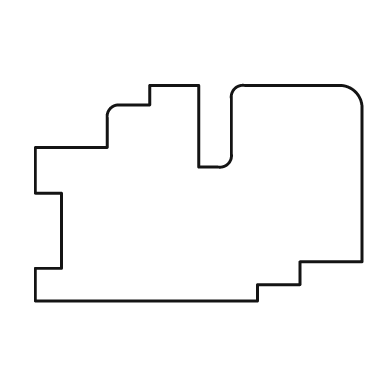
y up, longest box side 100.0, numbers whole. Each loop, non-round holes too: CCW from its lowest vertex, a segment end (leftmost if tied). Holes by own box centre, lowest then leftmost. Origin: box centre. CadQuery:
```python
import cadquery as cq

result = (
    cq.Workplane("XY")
    .moveTo(-50.0, -33.0)
    .lineTo(18.0, -33.0)
    .lineTo(18.0, -28.0)
    .lineTo(31.0, -28.0)
    .lineTo(31.0, -21.0)
    .lineTo(50.0, -21.0)
    .lineTo(50.0, 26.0)
    .threePointArc((48.0, 31.0), (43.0, 33.0))
    .lineTo(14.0, 33.0)
    .threePointArc((11.0, 32.0), (10.0, 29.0))
    .lineTo(10.0, 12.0)
    .threePointArc((9.0, 9.0), (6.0, 8.0))
    .lineTo(0.0, 8.0)
    .lineTo(0.0, 33.0)
    .lineTo(-15.0, 33.0)
    .lineTo(-15.0, 27.0)
    .lineTo(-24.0, 27.0)
    .threePointArc((-27.0, 26.0), (-28.0, 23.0))
    .lineTo(-28.0, 14.0)
    .lineTo(-50.0, 14.0)
    .lineTo(-50.0, 0.0)
    .lineTo(-42.0, 0.0)
    .lineTo(-42.0, -23.0)
    .lineTo(-50.0, -23.0)
    .close()
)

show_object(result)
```